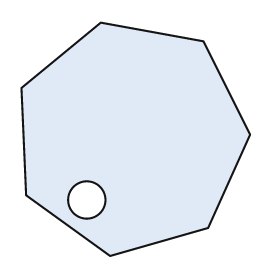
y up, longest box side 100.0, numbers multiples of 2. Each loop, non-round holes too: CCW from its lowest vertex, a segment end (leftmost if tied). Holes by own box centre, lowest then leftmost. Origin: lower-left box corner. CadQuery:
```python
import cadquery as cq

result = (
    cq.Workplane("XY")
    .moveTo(38.0, 0.0)
    .lineTo(80.0, 12.0)
    .lineTo(98.0, 52.0)
    .lineTo(78.0, 92.0)
    .lineTo(34.0, 100.0)
    .lineTo(0.0, 72.0)
    .lineTo(2.0, 26.0)
    .close()
    .moveTo(28.0, 24.0)
    .circle(8.0)
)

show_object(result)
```